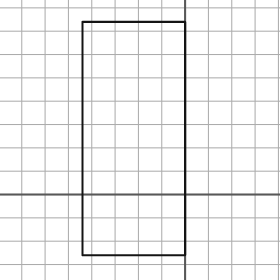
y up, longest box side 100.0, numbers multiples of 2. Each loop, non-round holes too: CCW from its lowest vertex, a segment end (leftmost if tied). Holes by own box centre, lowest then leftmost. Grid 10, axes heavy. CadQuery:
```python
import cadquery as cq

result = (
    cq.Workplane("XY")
    .moveTo(-44.0, -26.0)
    .lineTo(0.0, -26.0)
    .lineTo(0.0, 74.0)
    .lineTo(-44.0, 74.0)
    .close()
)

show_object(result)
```